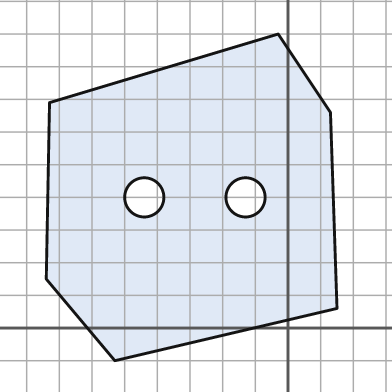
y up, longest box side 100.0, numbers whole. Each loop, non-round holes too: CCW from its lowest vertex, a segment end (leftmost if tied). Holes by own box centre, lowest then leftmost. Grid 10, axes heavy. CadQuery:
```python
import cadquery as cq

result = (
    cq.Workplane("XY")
    .moveTo(-53.0, -10.0)
    .lineTo(15.0, 6.0)
    .lineTo(13.0, 66.0)
    .lineTo(-3.0, 90.0)
    .lineTo(-73.0, 69.0)
    .lineTo(-74.0, 15.0)
    .close()
    .moveTo(-44.0, 40.0)
    .circle(6.0)
    .moveTo(-13.0, 40.0)
    .circle(6.0)
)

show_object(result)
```